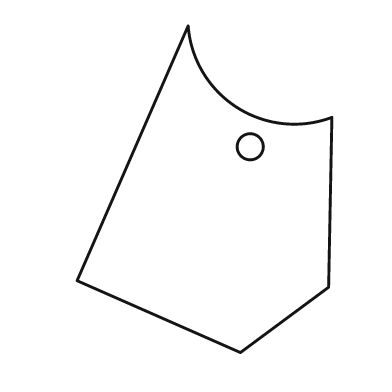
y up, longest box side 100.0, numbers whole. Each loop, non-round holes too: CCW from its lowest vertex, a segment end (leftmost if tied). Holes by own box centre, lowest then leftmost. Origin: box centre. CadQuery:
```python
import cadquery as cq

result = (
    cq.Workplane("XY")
    .moveTo(11.0, -50.0)
    .lineTo(38.0, -30.0)
    .lineTo(39.0, 22.0)
    .threePointArc((10.0, 25.0), (-5.0, 50.0))
    .lineTo(-39.0, -28.0)
    .close()
    .moveTo(14.0, 13.0)
    .circle(4.0)
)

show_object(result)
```